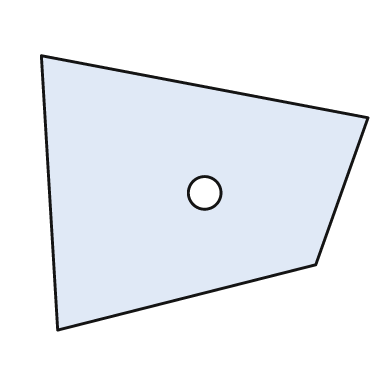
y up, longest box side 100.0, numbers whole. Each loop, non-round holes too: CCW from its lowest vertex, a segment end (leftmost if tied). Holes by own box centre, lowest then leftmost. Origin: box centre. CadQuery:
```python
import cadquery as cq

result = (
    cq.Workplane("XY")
    .moveTo(-45.0, -42.0)
    .lineTo(34.0, -22.0)
    .lineTo(50.0, 23.0)
    .lineTo(-50.0, 42.0)
    .close()
    .moveTo(0.0, 0.0)
    .circle(5.0)
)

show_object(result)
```